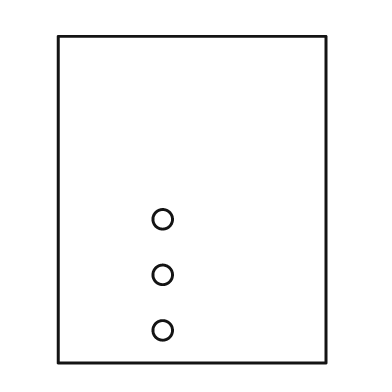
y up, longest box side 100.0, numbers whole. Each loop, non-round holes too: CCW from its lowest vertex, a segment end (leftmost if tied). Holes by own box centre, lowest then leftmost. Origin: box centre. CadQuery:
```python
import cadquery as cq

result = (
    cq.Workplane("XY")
    .moveTo(-41.0, -50.0)
    .lineTo(41.0, -50.0)
    .lineTo(41.0, 50.0)
    .lineTo(-41.0, 50.0)
    .close()
    .moveTo(-9.0, -40.0)
    .circle(3.0)
    .moveTo(-9.0, -23.0)
    .circle(3.0)
    .moveTo(-9.0, -6.0)
    .circle(3.0)
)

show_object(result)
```